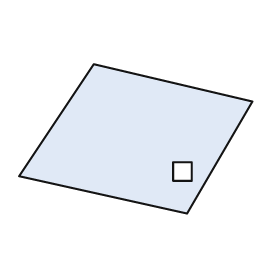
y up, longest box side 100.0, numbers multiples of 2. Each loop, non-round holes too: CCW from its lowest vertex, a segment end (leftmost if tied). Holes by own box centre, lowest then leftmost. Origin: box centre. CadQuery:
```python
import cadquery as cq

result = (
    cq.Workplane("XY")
    .moveTo(22.0, -32.0)
    .lineTo(50.0, 16.0)
    .lineTo(-18.0, 32.0)
    .lineTo(-50.0, -16.0)
    .close()
    .moveTo(16.0, -18.0)
    .lineTo(24.0, -18.0)
    .lineTo(24.0, -10.0)
    .lineTo(16.0, -10.0)
    .close()
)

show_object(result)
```